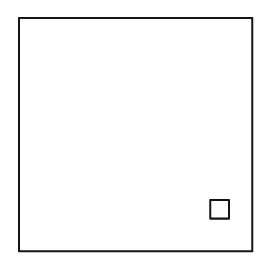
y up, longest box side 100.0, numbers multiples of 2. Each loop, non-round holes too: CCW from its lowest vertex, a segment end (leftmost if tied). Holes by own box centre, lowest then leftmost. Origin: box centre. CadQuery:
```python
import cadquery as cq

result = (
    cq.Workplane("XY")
    .moveTo(-50.0, -50.0)
    .lineTo(50.0, -50.0)
    .lineTo(50.0, 50.0)
    .lineTo(-50.0, 50.0)
    .close()
    .moveTo(32.0, -36.0)
    .lineTo(40.0, -36.0)
    .lineTo(40.0, -28.0)
    .lineTo(32.0, -28.0)
    .close()
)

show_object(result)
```